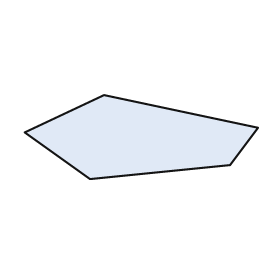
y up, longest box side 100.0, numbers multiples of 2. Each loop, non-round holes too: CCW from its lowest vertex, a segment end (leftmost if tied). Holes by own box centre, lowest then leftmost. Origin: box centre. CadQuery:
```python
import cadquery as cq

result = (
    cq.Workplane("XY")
    .moveTo(-22.0, -18.0)
    .lineTo(38.0, -12.0)
    .lineTo(50.0, 4.0)
    .lineTo(-16.0, 18.0)
    .lineTo(-50.0, 2.0)
    .close()
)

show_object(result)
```